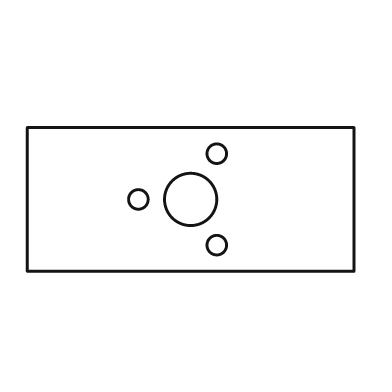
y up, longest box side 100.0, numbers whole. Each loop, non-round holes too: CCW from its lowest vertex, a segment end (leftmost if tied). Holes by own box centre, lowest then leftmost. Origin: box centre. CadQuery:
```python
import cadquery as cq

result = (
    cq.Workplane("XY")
    .moveTo(-50.0, -22.0)
    .lineTo(50.0, -22.0)
    .lineTo(50.0, 22.0)
    .lineTo(-50.0, 22.0)
    .close()
    .moveTo(8.0, -14.0)
    .circle(3.0)
    .moveTo(-16.0, 0.0)
    .circle(3.0)
    .moveTo(0.0, 0.0)
    .circle(8.0)
    .moveTo(8.0, 14.0)
    .circle(3.0)
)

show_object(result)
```